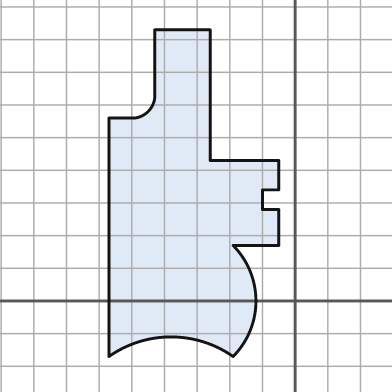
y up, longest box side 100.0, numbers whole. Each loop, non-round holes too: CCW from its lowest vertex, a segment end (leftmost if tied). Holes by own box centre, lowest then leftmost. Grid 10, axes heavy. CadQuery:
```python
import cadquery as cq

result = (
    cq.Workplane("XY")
    .moveTo(-57.0, -17.0)
    .threePointArc((-38.0, -11.0), (-19.0, -17.0))
    .threePointArc((-12.0, 0.0), (-19.0, 17.0))
    .lineTo(-5.0, 17.0)
    .lineTo(-5.0, 28.0)
    .lineTo(-10.0, 28.0)
    .lineTo(-10.0, 34.0)
    .lineTo(-5.0, 34.0)
    .lineTo(-5.0, 43.0)
    .lineTo(-26.0, 43.0)
    .lineTo(-26.0, 83.0)
    .lineTo(-43.0, 83.0)
    .lineTo(-43.0, 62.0)
    .threePointArc((-45.0, 58.0), (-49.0, 56.0))
    .lineTo(-57.0, 56.0)
    .close()
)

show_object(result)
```